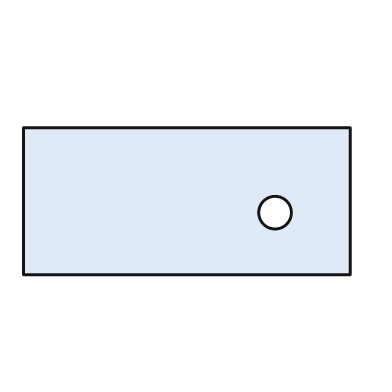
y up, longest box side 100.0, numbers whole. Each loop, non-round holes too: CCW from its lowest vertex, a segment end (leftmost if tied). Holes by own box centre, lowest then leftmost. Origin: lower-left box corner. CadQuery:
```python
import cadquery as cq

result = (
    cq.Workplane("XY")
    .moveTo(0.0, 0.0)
    .lineTo(100.0, 0.0)
    .lineTo(100.0, 45.0)
    .lineTo(0.0, 45.0)
    .close()
    .moveTo(77.0, 19.0)
    .circle(5.0)
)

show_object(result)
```